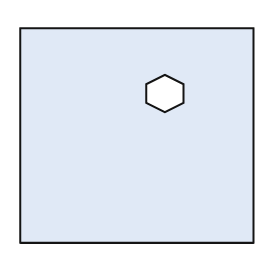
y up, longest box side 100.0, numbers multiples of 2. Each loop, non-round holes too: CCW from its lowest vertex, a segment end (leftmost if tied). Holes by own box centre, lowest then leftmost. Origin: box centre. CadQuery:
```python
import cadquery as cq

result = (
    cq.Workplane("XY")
    .moveTo(-50.0, -46.0)
    .lineTo(50.0, -46.0)
    .lineTo(50.0, 46.0)
    .lineTo(-50.0, 46.0)
    .close()
    .moveTo(12.0, 10.0)
    .lineTo(20.0, 14.0)
    .lineTo(20.0, 22.0)
    .lineTo(12.0, 26.0)
    .lineTo(4.0, 22.0)
    .lineTo(4.0, 14.0)
    .close()
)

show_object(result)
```